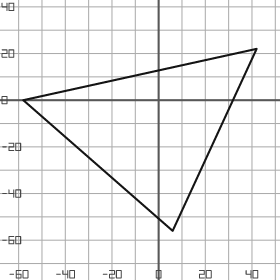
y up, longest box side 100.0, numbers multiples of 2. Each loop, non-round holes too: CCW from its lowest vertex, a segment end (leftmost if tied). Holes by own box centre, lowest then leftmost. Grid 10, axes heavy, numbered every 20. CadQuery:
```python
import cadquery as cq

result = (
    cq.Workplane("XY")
    .moveTo(6.0, -56.0)
    .lineTo(42.0, 22.0)
    .lineTo(-58.0, 0.0)
    .close()
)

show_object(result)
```